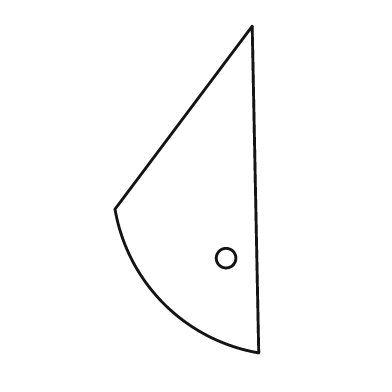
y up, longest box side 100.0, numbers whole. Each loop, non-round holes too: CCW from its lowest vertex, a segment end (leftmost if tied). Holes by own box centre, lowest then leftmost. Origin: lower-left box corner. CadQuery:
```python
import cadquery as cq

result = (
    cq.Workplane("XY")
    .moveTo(44.0, 0.0)
    .lineTo(42.0, 100.0)
    .lineTo(0.0, 44.0)
    .threePointArc((15.0, 15.0), (44.0, 0.0))
    .close()
    .moveTo(34.0, 29.0)
    .circle(3.0)
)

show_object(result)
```